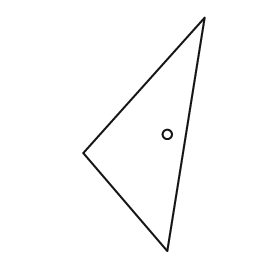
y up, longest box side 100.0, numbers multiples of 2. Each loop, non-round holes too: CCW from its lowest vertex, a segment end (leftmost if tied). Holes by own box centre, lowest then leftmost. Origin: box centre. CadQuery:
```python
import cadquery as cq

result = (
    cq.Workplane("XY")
    .moveTo(10.0, -50.0)
    .lineTo(26.0, 50.0)
    .lineTo(-26.0, -8.0)
    .close()
    .moveTo(10.0, 0.0)
    .circle(2.0)
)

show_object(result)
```